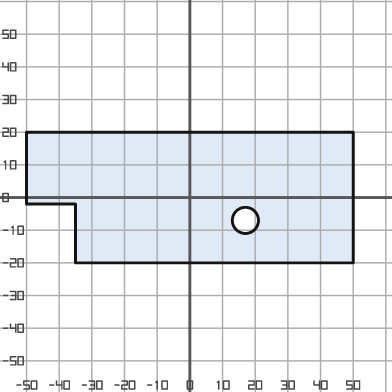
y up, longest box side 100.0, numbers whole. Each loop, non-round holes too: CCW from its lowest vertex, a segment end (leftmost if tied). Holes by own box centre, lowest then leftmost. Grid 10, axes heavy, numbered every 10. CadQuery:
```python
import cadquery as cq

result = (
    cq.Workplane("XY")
    .moveTo(-35.0, -20.0)
    .lineTo(50.0, -20.0)
    .lineTo(50.0, 20.0)
    .lineTo(-50.0, 20.0)
    .lineTo(-50.0, -2.0)
    .lineTo(-35.0, -2.0)
    .close()
    .moveTo(17.0, -7.0)
    .circle(4.0)
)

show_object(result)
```